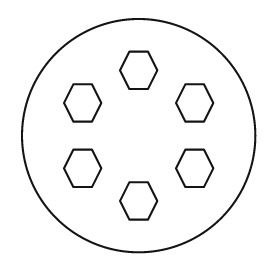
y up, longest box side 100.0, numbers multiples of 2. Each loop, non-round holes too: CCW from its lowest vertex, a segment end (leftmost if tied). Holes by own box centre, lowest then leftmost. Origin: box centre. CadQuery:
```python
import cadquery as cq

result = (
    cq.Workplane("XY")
    .moveTo(0.0, 0.0)
    .circle(50.0)
    .moveTo(-4.0, -36.0)
    .lineTo(4.0, -36.0)
    .lineTo(8.0, -28.0)
    .lineTo(4.0, -20.0)
    .lineTo(-4.0, -20.0)
    .lineTo(-8.0, -28.0)
    .close()
    .moveTo(-28.0, -22.0)
    .lineTo(-20.0, -22.0)
    .lineTo(-16.0, -14.0)
    .lineTo(-20.0, -6.0)
    .lineTo(-28.0, -6.0)
    .lineTo(-32.0, -14.0)
    .close()
    .moveTo(20.0, -22.0)
    .lineTo(28.0, -22.0)
    .lineTo(32.0, -14.0)
    .lineTo(28.0, -6.0)
    .lineTo(20.0, -6.0)
    .lineTo(16.0, -14.0)
    .close()
    .moveTo(-28.0, 6.0)
    .lineTo(-20.0, 6.0)
    .lineTo(-16.0, 14.0)
    .lineTo(-20.0, 22.0)
    .lineTo(-28.0, 22.0)
    .lineTo(-32.0, 14.0)
    .close()
    .moveTo(20.0, 6.0)
    .lineTo(28.0, 6.0)
    .lineTo(32.0, 14.0)
    .lineTo(28.0, 22.0)
    .lineTo(20.0, 22.0)
    .lineTo(16.0, 14.0)
    .close()
    .moveTo(-4.0, 20.0)
    .lineTo(4.0, 20.0)
    .lineTo(8.0, 28.0)
    .lineTo(4.0, 36.0)
    .lineTo(-4.0, 36.0)
    .lineTo(-8.0, 28.0)
    .close()
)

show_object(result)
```